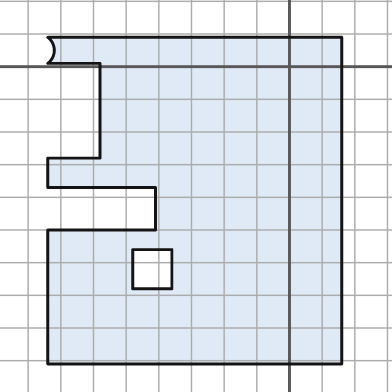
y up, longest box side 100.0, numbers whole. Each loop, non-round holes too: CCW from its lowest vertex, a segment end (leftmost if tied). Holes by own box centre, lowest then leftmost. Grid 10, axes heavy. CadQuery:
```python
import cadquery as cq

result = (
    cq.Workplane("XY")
    .moveTo(-74.0, -91.0)
    .lineTo(16.0, -91.0)
    .lineTo(16.0, 9.0)
    .lineTo(-74.0, 9.0)
    .threePointArc((-72.0, 5.0), (-74.0, 1.0))
    .lineTo(-58.0, 1.0)
    .lineTo(-58.0, -28.0)
    .lineTo(-74.0, -28.0)
    .lineTo(-74.0, -37.0)
    .lineTo(-41.0, -37.0)
    .lineTo(-41.0, -50.0)
    .lineTo(-74.0, -50.0)
    .close()
    .moveTo(-48.0, -68.0)
    .lineTo(-36.0, -68.0)
    .lineTo(-36.0, -56.0)
    .lineTo(-48.0, -56.0)
    .close()
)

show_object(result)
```